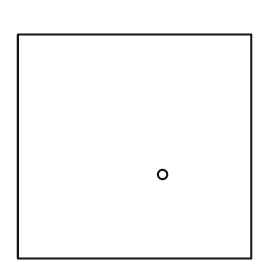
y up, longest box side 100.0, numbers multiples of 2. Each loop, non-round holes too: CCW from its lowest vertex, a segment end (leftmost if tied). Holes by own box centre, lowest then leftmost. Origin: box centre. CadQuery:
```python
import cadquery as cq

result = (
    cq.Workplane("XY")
    .moveTo(-50.0, -48.0)
    .lineTo(50.0, -48.0)
    .lineTo(50.0, 48.0)
    .lineTo(-50.0, 48.0)
    .close()
    .moveTo(12.0, -12.0)
    .circle(2.0)
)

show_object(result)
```